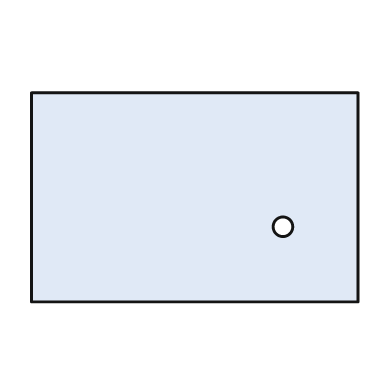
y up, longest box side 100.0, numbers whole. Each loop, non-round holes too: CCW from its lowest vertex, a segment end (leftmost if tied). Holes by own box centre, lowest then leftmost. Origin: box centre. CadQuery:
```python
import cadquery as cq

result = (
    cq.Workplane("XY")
    .moveTo(-50.0, -32.0)
    .lineTo(50.0, -32.0)
    .lineTo(50.0, 32.0)
    .lineTo(-50.0, 32.0)
    .close()
    .moveTo(27.0, -9.0)
    .circle(3.0)
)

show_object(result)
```